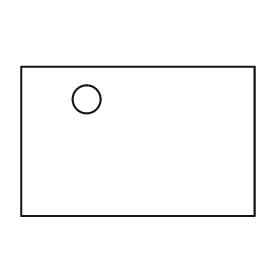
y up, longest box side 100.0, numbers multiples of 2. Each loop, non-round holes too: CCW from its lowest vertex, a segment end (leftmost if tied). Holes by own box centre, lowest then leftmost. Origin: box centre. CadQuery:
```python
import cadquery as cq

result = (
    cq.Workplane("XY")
    .moveTo(-50.0, -32.0)
    .lineTo(50.0, -32.0)
    .lineTo(50.0, 32.0)
    .lineTo(-50.0, 32.0)
    .close()
    .moveTo(-22.0, 18.0)
    .circle(6.0)
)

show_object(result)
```